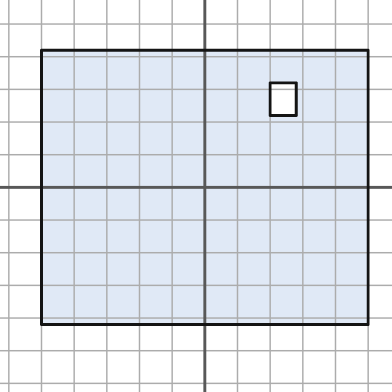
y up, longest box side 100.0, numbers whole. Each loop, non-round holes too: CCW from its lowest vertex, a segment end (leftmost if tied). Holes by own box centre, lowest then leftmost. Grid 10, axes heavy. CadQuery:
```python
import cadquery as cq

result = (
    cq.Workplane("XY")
    .moveTo(-50.0, -42.0)
    .lineTo(50.0, -42.0)
    .lineTo(50.0, 42.0)
    .lineTo(-50.0, 42.0)
    .close()
    .moveTo(20.0, 22.0)
    .lineTo(28.0, 22.0)
    .lineTo(28.0, 32.0)
    .lineTo(20.0, 32.0)
    .close()
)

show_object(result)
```